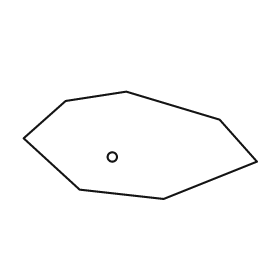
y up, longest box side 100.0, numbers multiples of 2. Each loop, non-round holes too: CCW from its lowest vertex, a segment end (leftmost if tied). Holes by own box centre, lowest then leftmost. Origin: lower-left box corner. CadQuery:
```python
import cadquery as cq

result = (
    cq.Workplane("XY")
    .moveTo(60.0, 0.0)
    .lineTo(100.0, 16.0)
    .lineTo(84.0, 34.0)
    .lineTo(44.0, 46.0)
    .lineTo(18.0, 42.0)
    .lineTo(0.0, 26.0)
    .lineTo(24.0, 4.0)
    .close()
    .moveTo(38.0, 18.0)
    .circle(2.0)
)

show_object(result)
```